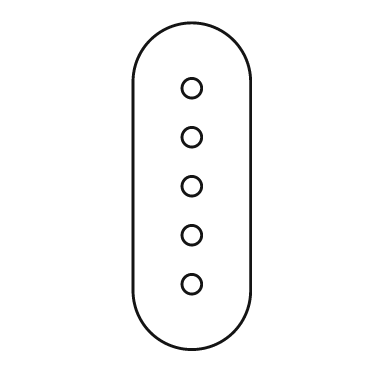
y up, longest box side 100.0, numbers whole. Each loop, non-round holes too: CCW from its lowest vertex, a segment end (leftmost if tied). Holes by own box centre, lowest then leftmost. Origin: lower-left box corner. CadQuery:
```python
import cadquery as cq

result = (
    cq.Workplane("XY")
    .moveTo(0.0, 18.0)
    .threePointArc((18.0, 0.0), (36.0, 18.0))
    .lineTo(36.0, 82.0)
    .threePointArc((18.0, 100.0), (0.0, 82.0))
    .close()
    .moveTo(18.0, 20.0)
    .circle(3.0)
    .moveTo(18.0, 35.0)
    .circle(3.0)
    .moveTo(18.0, 50.0)
    .circle(3.0)
    .moveTo(18.0, 65.0)
    .circle(3.0)
    .moveTo(18.0, 80.0)
    .circle(3.0)
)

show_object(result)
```